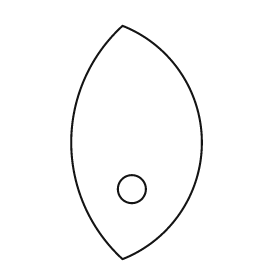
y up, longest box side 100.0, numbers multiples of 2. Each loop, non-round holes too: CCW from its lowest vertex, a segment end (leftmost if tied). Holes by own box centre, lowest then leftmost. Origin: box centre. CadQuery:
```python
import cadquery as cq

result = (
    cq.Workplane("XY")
    .moveTo(-6.0, -50.0)
    .threePointArc((28.0, 0.0), (-6.0, 50.0))
    .threePointArc((-28.0, 0.0), (-6.0, -50.0))
    .close()
    .moveTo(-2.0, -20.0)
    .circle(6.0)
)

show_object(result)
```